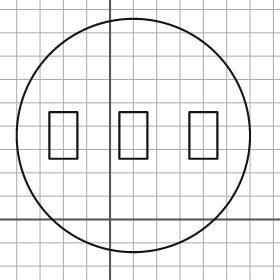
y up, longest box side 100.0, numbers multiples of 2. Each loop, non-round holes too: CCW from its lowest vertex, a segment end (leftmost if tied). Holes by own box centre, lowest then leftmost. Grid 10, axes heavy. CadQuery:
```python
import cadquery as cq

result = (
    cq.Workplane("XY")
    .moveTo(10.0, 36.0)
    .circle(50.0)
    .moveTo(-26.0, 26.0)
    .lineTo(-14.0, 26.0)
    .lineTo(-14.0, 46.0)
    .lineTo(-26.0, 46.0)
    .close()
    .moveTo(4.0, 26.0)
    .lineTo(16.0, 26.0)
    .lineTo(16.0, 46.0)
    .lineTo(4.0, 46.0)
    .close()
    .moveTo(34.0, 26.0)
    .lineTo(46.0, 26.0)
    .lineTo(46.0, 46.0)
    .lineTo(34.0, 46.0)
    .close()
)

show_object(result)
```